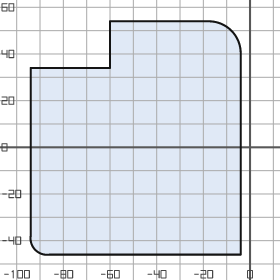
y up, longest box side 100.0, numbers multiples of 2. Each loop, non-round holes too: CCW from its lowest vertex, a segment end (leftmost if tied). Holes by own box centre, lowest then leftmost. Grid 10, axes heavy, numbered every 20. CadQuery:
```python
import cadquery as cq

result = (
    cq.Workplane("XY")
    .moveTo(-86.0, -46.0)
    .lineTo(-4.0, -46.0)
    .lineTo(-4.0, 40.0)
    .threePointArc((-8.0, 50.0), (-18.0, 54.0))
    .lineTo(-60.0, 54.0)
    .lineTo(-60.0, 34.0)
    .lineTo(-94.0, 34.0)
    .lineTo(-94.0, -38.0)
    .threePointArc((-92.0, -44.0), (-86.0, -46.0))
    .close()
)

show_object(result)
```